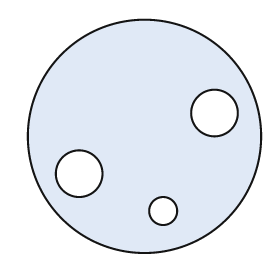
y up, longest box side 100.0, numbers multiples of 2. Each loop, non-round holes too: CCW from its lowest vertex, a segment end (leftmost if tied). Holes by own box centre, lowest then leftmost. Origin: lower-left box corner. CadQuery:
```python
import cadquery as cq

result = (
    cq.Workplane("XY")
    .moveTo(50.0, 50.0)
    .circle(50.0)
    .moveTo(58.0, 18.0)
    .circle(6.0)
    .moveTo(22.0, 34.0)
    .circle(10.0)
    .moveTo(80.0, 60.0)
    .circle(10.0)
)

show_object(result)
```